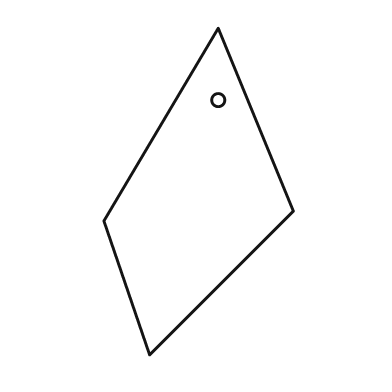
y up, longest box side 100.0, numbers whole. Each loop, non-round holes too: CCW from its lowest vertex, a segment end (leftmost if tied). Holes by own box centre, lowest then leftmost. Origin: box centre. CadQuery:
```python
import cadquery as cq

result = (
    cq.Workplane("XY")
    .moveTo(-15.0, -50.0)
    .lineTo(29.0, -6.0)
    .lineTo(6.0, 50.0)
    .lineTo(-29.0, -9.0)
    .close()
    .moveTo(6.0, 28.0)
    .circle(2.0)
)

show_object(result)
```